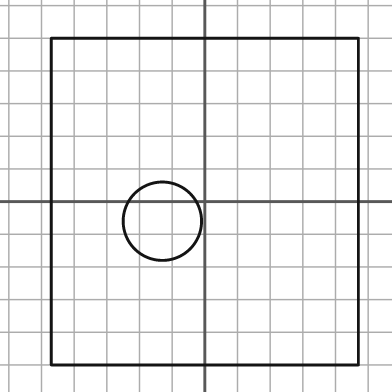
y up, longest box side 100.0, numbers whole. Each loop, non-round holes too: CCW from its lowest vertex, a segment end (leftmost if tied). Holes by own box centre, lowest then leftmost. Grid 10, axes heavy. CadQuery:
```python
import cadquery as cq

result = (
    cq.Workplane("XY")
    .moveTo(-47.0, -50.0)
    .lineTo(47.0, -50.0)
    .lineTo(47.0, 50.0)
    .lineTo(-47.0, 50.0)
    .close()
    .moveTo(-13.0, -6.0)
    .circle(12.0)
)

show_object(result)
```